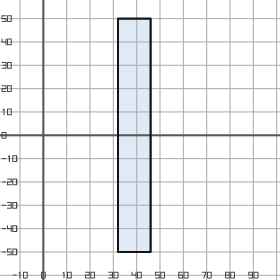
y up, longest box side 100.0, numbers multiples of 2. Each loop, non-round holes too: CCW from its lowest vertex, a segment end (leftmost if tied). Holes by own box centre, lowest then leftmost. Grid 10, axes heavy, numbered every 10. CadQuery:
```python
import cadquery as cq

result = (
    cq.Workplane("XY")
    .moveTo(32.0, -50.0)
    .lineTo(46.0, -50.0)
    .lineTo(46.0, 50.0)
    .lineTo(32.0, 50.0)
    .close()
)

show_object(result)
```